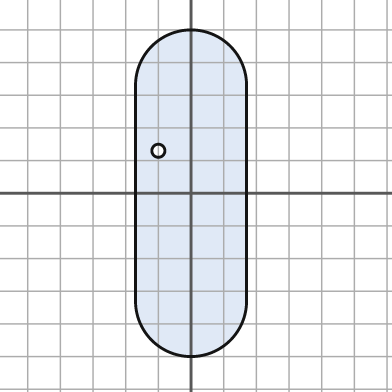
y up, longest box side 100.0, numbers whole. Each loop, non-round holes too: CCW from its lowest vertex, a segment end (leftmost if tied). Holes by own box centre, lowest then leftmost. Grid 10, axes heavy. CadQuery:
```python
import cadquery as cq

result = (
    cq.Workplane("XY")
    .moveTo(-17.0, -33.0)
    .threePointArc((0.0, -50.0), (17.0, -33.0))
    .lineTo(17.0, 33.0)
    .threePointArc((0.0, 50.0), (-17.0, 33.0))
    .close()
    .moveTo(-10.0, 13.0)
    .circle(2.0)
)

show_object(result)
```